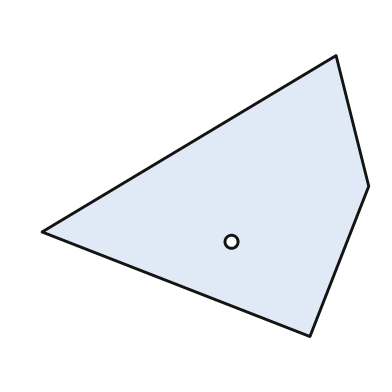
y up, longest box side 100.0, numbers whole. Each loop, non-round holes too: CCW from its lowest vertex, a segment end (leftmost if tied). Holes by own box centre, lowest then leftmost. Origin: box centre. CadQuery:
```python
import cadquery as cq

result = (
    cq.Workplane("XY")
    .moveTo(32.0, -43.0)
    .lineTo(50.0, 3.0)
    .lineTo(40.0, 43.0)
    .lineTo(-50.0, -11.0)
    .close()
    .moveTo(8.0, -14.0)
    .circle(2.0)
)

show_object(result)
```